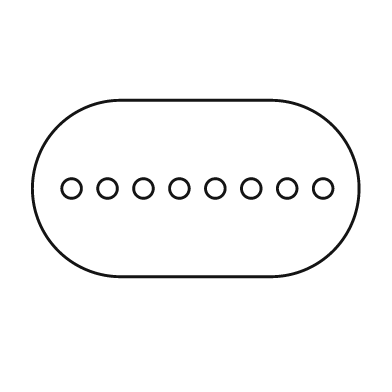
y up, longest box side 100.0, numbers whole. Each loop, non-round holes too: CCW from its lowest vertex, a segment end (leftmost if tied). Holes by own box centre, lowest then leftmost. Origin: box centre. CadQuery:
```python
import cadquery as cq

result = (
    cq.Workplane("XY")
    .moveTo(-23.0, -27.0)
    .lineTo(23.0, -27.0)
    .threePointArc((50.0, 0.0), (23.0, 27.0))
    .lineTo(-23.0, 27.0)
    .threePointArc((-50.0, 0.0), (-23.0, -27.0))
    .close()
    .moveTo(-38.0, 0.0)
    .circle(3.0)
    .moveTo(-27.0, 0.0)
    .circle(3.0)
    .moveTo(-16.0, 0.0)
    .circle(3.0)
    .moveTo(-5.0, 0.0)
    .circle(3.0)
    .moveTo(6.0, 0.0)
    .circle(3.0)
    .moveTo(17.0, 0.0)
    .circle(3.0)
    .moveTo(28.0, 0.0)
    .circle(3.0)
    .moveTo(39.0, 0.0)
    .circle(3.0)
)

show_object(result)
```